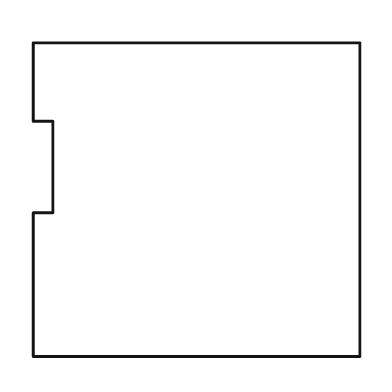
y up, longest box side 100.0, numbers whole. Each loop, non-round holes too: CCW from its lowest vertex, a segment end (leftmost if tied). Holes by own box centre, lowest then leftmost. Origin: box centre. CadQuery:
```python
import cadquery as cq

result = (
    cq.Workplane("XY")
    .moveTo(-50.0, -48.0)
    .lineTo(50.0, -48.0)
    .lineTo(50.0, 48.0)
    .lineTo(-50.0, 48.0)
    .lineTo(-50.0, 24.0)
    .lineTo(-44.0, 24.0)
    .lineTo(-44.0, -4.0)
    .lineTo(-50.0, -4.0)
    .close()
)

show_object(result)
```